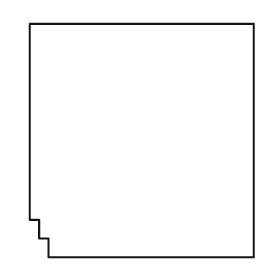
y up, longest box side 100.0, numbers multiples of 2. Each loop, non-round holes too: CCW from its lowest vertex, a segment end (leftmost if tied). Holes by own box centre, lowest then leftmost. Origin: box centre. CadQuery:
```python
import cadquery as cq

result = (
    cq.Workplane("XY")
    .moveTo(-40.0, -50.0)
    .lineTo(48.0, -50.0)
    .lineTo(48.0, 50.0)
    .lineTo(-48.0, 50.0)
    .lineTo(-48.0, -34.0)
    .lineTo(-44.0, -34.0)
    .lineTo(-44.0, -42.0)
    .lineTo(-40.0, -42.0)
    .close()
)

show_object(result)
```